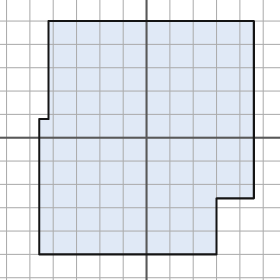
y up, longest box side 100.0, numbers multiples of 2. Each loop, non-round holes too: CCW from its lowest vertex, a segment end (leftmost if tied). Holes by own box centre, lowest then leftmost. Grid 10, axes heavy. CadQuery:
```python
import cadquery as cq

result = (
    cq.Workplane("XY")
    .moveTo(-46.0, -50.0)
    .lineTo(30.0, -50.0)
    .lineTo(30.0, -26.0)
    .lineTo(46.0, -26.0)
    .lineTo(46.0, 50.0)
    .lineTo(-42.0, 50.0)
    .lineTo(-42.0, 8.0)
    .lineTo(-46.0, 8.0)
    .close()
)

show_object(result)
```